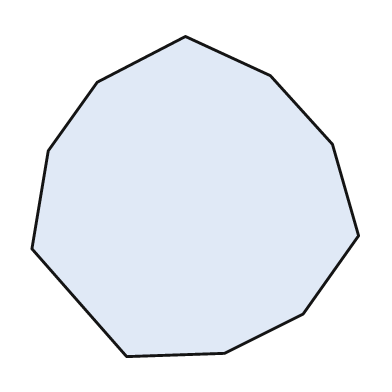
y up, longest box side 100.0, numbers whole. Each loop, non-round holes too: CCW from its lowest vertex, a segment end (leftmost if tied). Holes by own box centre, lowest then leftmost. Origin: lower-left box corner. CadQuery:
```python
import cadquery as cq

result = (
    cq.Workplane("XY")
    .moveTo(29.0, 0.0)
    .lineTo(59.0, 1.0)
    .lineTo(83.0, 13.0)
    .lineTo(100.0, 37.0)
    .lineTo(92.0, 65.0)
    .lineTo(73.0, 86.0)
    .lineTo(47.0, 98.0)
    .lineTo(20.0, 84.0)
    .lineTo(5.0, 63.0)
    .lineTo(0.0, 33.0)
    .close()
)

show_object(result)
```